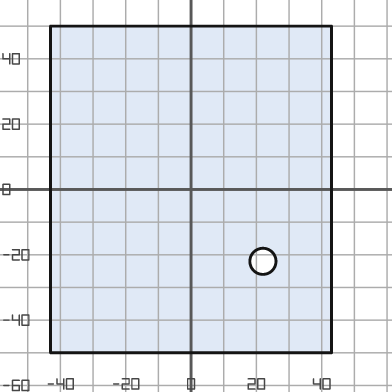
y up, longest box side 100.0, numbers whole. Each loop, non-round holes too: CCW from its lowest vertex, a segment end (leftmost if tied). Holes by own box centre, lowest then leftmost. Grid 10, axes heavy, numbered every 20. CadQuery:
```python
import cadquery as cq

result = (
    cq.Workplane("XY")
    .moveTo(-43.0, -50.0)
    .lineTo(43.0, -50.0)
    .lineTo(43.0, 50.0)
    .lineTo(-43.0, 50.0)
    .close()
    .moveTo(22.0, -22.0)
    .circle(4.0)
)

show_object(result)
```